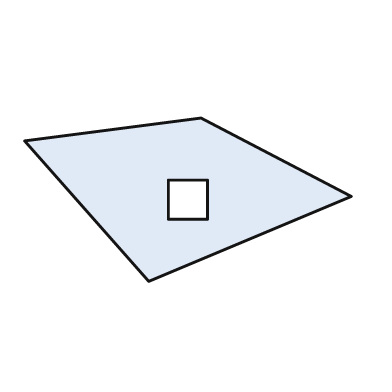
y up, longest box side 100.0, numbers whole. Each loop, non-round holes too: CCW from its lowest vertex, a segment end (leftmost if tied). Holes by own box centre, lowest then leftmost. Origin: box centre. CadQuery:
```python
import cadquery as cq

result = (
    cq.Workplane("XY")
    .moveTo(-12.0, -25.0)
    .lineTo(50.0, 1.0)
    .lineTo(4.0, 25.0)
    .lineTo(-50.0, 18.0)
    .close()
    .moveTo(-6.0, -6.0)
    .lineTo(6.0, -6.0)
    .lineTo(6.0, 6.0)
    .lineTo(-6.0, 6.0)
    .close()
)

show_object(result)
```